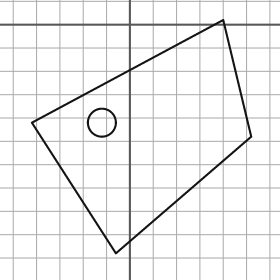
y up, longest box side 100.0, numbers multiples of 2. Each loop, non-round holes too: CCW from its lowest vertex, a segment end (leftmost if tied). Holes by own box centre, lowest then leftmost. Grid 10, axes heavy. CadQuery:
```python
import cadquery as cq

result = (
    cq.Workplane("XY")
    .moveTo(-6.0, -98.0)
    .lineTo(52.0, -48.0)
    .lineTo(40.0, 2.0)
    .lineTo(-42.0, -42.0)
    .close()
    .moveTo(-12.0, -42.0)
    .circle(6.0)
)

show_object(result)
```